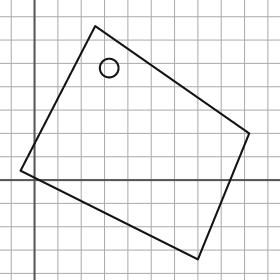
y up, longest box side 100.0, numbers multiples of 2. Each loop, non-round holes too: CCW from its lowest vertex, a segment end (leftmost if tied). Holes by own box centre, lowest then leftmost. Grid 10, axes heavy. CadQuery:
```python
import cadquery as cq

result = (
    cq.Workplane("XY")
    .moveTo(70.0, -34.0)
    .lineTo(92.0, 20.0)
    .lineTo(26.0, 66.0)
    .lineTo(-6.0, 4.0)
    .close()
    .moveTo(32.0, 48.0)
    .circle(4.0)
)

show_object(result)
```